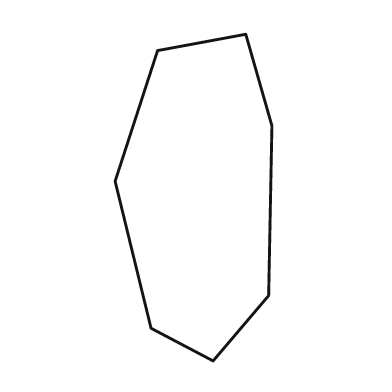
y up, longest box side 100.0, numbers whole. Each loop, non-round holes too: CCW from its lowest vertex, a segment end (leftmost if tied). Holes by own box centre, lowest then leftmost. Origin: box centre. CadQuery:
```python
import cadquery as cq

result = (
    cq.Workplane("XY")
    .moveTo(6.0, -50.0)
    .lineTo(23.0, -30.0)
    .lineTo(24.0, 22.0)
    .lineTo(16.0, 50.0)
    .lineTo(-11.0, 45.0)
    .lineTo(-24.0, 5.0)
    .lineTo(-13.0, -40.0)
    .close()
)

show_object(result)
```